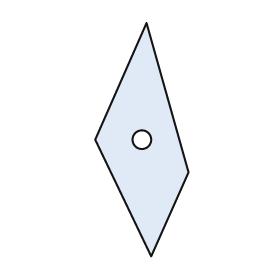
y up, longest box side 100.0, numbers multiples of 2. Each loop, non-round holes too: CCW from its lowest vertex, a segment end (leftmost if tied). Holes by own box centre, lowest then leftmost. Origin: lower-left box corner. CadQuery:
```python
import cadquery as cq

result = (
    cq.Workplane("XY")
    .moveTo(24.0, 0.0)
    .lineTo(40.0, 36.0)
    .lineTo(22.0, 100.0)
    .lineTo(0.0, 50.0)
    .close()
    .moveTo(20.0, 50.0)
    .circle(4.0)
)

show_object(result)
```